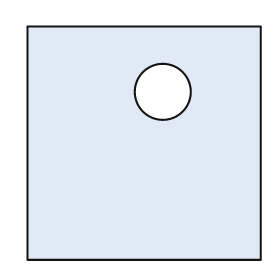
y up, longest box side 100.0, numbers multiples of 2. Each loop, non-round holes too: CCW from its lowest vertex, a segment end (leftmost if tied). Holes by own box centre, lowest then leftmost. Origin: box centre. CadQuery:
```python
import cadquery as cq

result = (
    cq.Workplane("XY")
    .moveTo(-50.0, -50.0)
    .lineTo(50.0, -50.0)
    .lineTo(50.0, 50.0)
    .lineTo(-50.0, 50.0)
    .close()
    .moveTo(8.0, 22.0)
    .circle(12.0)
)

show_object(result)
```